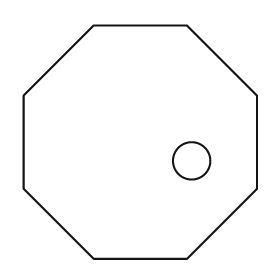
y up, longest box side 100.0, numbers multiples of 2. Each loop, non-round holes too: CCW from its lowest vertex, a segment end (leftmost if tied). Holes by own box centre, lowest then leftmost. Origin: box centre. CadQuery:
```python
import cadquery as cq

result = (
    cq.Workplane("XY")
    .moveTo(-20.0, -50.0)
    .lineTo(20.0, -50.0)
    .lineTo(50.0, -20.0)
    .lineTo(50.0, 20.0)
    .lineTo(20.0, 50.0)
    .lineTo(-20.0, 50.0)
    .lineTo(-50.0, 20.0)
    .lineTo(-50.0, -20.0)
    .close()
    .moveTo(22.0, -8.0)
    .circle(8.0)
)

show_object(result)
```